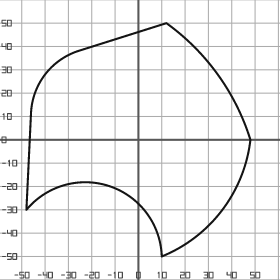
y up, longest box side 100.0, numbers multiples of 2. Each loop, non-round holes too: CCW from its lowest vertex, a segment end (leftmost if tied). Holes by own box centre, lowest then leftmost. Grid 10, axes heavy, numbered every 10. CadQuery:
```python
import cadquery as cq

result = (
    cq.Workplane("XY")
    .moveTo(10.0, -50.0)
    .threePointArc((36.0, -30.0), (48.0, 0.0))
    .threePointArc((34.0, 28.0), (12.0, 50.0))
    .lineTo(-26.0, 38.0)
    .threePointArc((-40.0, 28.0), (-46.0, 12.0))
    .lineTo(-48.0, -30.0)
    .threePointArc((-12.0, -20.0), (10.0, -50.0))
    .close()
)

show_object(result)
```